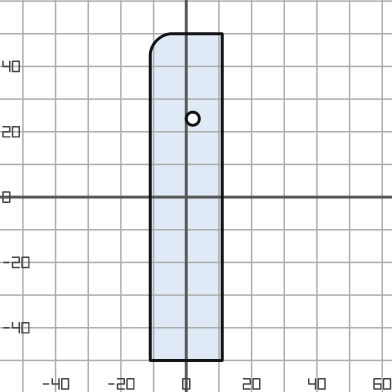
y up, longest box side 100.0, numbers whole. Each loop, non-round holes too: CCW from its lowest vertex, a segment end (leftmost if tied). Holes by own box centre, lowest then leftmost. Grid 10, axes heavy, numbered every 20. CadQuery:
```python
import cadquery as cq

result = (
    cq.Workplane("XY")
    .moveTo(-11.0, -50.0)
    .lineTo(11.0, -50.0)
    .lineTo(11.0, 50.0)
    .lineTo(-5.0, 50.0)
    .threePointArc((-9.0, 48.0), (-11.0, 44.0))
    .close()
    .moveTo(2.0, 24.0)
    .circle(2.0)
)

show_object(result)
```